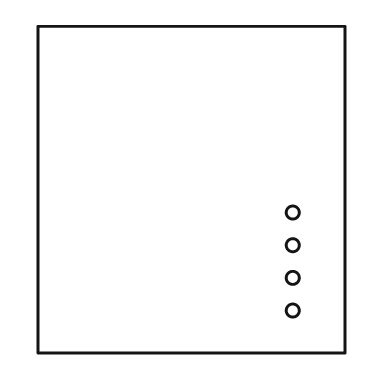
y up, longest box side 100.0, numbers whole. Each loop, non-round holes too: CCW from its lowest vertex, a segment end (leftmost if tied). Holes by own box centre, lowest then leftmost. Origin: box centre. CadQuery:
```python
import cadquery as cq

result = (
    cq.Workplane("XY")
    .moveTo(-47.0, -50.0)
    .lineTo(47.0, -50.0)
    .lineTo(47.0, 50.0)
    .lineTo(-47.0, 50.0)
    .close()
    .moveTo(31.0, -37.0)
    .circle(2.0)
    .moveTo(31.0, -27.0)
    .circle(2.0)
    .moveTo(31.0, -17.0)
    .circle(2.0)
    .moveTo(31.0, -7.0)
    .circle(2.0)
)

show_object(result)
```